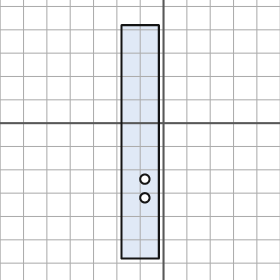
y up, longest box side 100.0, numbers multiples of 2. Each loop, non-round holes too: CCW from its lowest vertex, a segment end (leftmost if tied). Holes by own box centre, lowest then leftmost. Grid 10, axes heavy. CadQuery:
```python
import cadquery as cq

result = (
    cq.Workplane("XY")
    .moveTo(-18.0, -58.0)
    .lineTo(-2.0, -58.0)
    .lineTo(-2.0, 42.0)
    .lineTo(-18.0, 42.0)
    .close()
    .moveTo(-8.0, -32.0)
    .circle(2.0)
    .moveTo(-8.0, -24.0)
    .circle(2.0)
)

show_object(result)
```